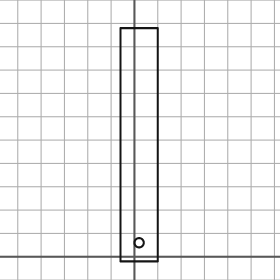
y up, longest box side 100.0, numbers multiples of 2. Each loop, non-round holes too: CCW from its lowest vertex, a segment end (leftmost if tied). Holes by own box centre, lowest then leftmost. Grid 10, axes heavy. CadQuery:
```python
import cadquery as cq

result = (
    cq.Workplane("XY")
    .moveTo(-6.0, -2.0)
    .lineTo(10.0, -2.0)
    .lineTo(10.0, 98.0)
    .lineTo(-6.0, 98.0)
    .close()
    .moveTo(2.0, 6.0)
    .circle(2.0)
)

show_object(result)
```